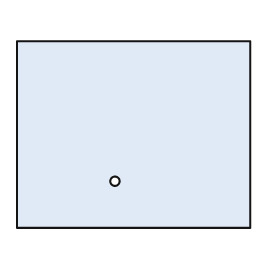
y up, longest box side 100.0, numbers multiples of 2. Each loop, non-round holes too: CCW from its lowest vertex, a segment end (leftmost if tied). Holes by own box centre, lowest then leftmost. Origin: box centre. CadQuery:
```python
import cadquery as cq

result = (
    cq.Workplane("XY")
    .moveTo(-50.0, -40.0)
    .lineTo(50.0, -40.0)
    .lineTo(50.0, 40.0)
    .lineTo(-50.0, 40.0)
    .close()
    .moveTo(-8.0, -20.0)
    .circle(2.0)
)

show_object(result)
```